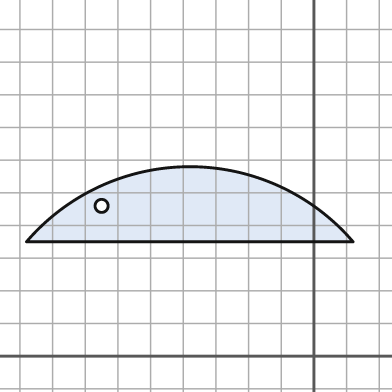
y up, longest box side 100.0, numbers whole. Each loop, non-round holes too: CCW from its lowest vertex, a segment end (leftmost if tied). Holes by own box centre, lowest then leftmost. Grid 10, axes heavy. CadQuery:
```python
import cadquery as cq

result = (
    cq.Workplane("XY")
    .moveTo(-88.0, 35.0)
    .lineTo(12.0, 35.0)
    .threePointArc((-38.0, 58.0), (-88.0, 35.0))
    .close()
    .moveTo(-65.0, 46.0)
    .circle(2.0)
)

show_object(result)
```